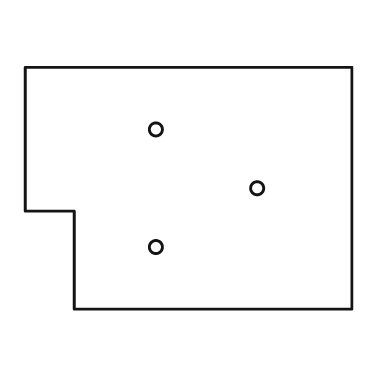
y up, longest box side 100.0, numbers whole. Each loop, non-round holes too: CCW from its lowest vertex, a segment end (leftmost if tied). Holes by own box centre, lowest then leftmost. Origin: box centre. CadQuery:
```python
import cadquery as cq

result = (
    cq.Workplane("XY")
    .moveTo(-35.0, -37.0)
    .lineTo(50.0, -37.0)
    .lineTo(50.0, 37.0)
    .lineTo(-50.0, 37.0)
    .lineTo(-50.0, -7.0)
    .lineTo(-35.0, -7.0)
    .close()
    .moveTo(-10.0, -18.0)
    .circle(2.0)
    .moveTo(21.0, 0.0)
    .circle(2.0)
    .moveTo(-10.0, 18.0)
    .circle(2.0)
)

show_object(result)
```